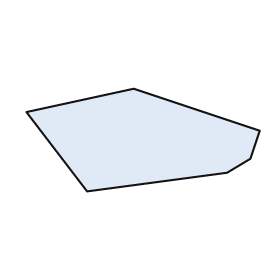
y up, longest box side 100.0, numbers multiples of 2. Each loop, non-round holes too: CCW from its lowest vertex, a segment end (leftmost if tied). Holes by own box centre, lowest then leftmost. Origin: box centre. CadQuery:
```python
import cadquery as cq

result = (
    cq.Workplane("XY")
    .moveTo(-24.0, -22.0)
    .lineTo(36.0, -14.0)
    .lineTo(46.0, -8.0)
    .lineTo(50.0, 4.0)
    .lineTo(-4.0, 22.0)
    .lineTo(-50.0, 12.0)
    .close()
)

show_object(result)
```